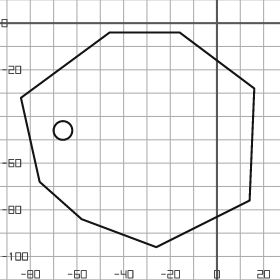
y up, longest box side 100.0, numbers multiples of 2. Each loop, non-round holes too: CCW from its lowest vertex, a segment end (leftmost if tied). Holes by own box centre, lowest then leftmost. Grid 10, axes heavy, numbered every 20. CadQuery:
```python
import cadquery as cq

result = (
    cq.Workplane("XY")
    .moveTo(-26.0, -96.0)
    .lineTo(14.0, -76.0)
    .lineTo(16.0, -28.0)
    .lineTo(-16.0, -4.0)
    .lineTo(-46.0, -4.0)
    .lineTo(-84.0, -32.0)
    .lineTo(-76.0, -68.0)
    .lineTo(-58.0, -84.0)
    .close()
    .moveTo(-66.0, -46.0)
    .circle(4.0)
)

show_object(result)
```